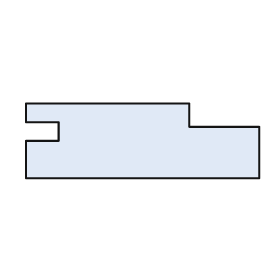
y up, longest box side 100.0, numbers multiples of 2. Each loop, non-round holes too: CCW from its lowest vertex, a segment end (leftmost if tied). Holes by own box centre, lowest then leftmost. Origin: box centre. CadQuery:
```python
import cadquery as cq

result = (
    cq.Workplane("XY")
    .moveTo(-50.0, -16.0)
    .lineTo(50.0, -16.0)
    .lineTo(50.0, 6.0)
    .lineTo(20.0, 6.0)
    .lineTo(20.0, 16.0)
    .lineTo(-50.0, 16.0)
    .lineTo(-50.0, 8.0)
    .lineTo(-36.0, 8.0)
    .lineTo(-36.0, 0.0)
    .lineTo(-50.0, 0.0)
    .close()
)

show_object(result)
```